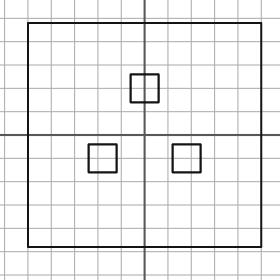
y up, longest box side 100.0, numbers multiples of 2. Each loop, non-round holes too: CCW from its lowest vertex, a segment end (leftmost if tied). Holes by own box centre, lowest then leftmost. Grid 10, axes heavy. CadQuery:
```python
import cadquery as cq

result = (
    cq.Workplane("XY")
    .moveTo(-50.0, -48.0)
    .lineTo(50.0, -48.0)
    .lineTo(50.0, 48.0)
    .lineTo(-50.0, 48.0)
    .close()
    .moveTo(-24.0, -16.0)
    .lineTo(-12.0, -16.0)
    .lineTo(-12.0, -4.0)
    .lineTo(-24.0, -4.0)
    .close()
    .moveTo(12.0, -16.0)
    .lineTo(24.0, -16.0)
    .lineTo(24.0, -4.0)
    .lineTo(12.0, -4.0)
    .close()
    .moveTo(-6.0, 14.0)
    .lineTo(6.0, 14.0)
    .lineTo(6.0, 26.0)
    .lineTo(-6.0, 26.0)
    .close()
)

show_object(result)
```